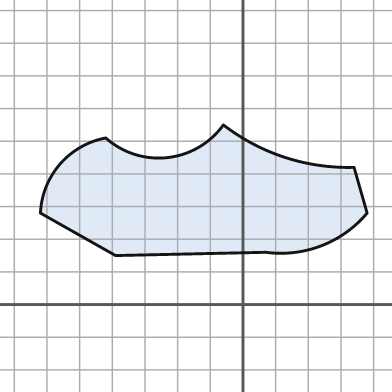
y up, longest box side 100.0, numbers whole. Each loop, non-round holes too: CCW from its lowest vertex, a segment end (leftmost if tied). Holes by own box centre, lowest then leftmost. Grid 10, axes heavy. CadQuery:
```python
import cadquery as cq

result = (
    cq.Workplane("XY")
    .moveTo(-39.0, 15.0)
    .lineTo(7.0, 16.0)
    .threePointArc((24.0, 18.0), (38.0, 28.0))
    .lineTo(34.0, 42.0)
    .threePointArc((13.0, 45.0), (-6.0, 55.0))
    .threePointArc((-23.0, 45.0), (-42.0, 51.0))
    .threePointArc((-56.0, 43.0), (-62.0, 28.0))
    .close()
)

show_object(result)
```